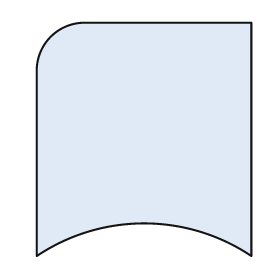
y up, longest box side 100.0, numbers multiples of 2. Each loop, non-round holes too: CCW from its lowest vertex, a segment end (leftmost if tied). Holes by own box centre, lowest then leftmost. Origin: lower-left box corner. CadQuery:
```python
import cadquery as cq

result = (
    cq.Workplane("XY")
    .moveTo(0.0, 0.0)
    .threePointArc((46.0, 14.0), (92.0, 0.0))
    .lineTo(92.0, 100.0)
    .lineTo(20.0, 100.0)
    .threePointArc((6.0, 94.0), (0.0, 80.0))
    .close()
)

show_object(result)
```